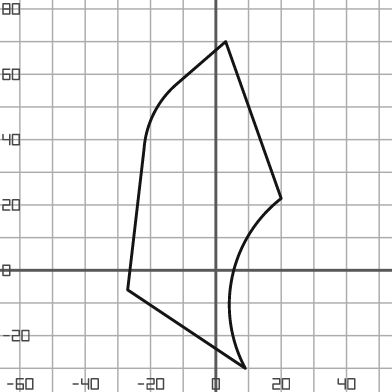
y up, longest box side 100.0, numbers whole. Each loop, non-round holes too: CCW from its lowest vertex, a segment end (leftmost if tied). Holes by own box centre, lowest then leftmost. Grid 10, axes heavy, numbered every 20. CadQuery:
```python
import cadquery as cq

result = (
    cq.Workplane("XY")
    .moveTo(9.0, -30.0)
    .threePointArc((5.0, -2.0), (20.0, 22.0))
    .lineTo(3.0, 70.0)
    .lineTo(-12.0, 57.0)
    .threePointArc((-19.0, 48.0), (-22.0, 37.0))
    .lineTo(-27.0, -6.0)
    .close()
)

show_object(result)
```